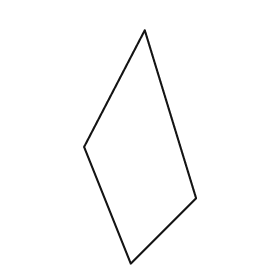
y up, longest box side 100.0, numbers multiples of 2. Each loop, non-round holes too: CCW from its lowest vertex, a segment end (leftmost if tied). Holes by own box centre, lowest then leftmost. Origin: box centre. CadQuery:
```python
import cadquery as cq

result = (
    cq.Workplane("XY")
    .moveTo(-4.0, -50.0)
    .lineTo(24.0, -22.0)
    .lineTo(2.0, 50.0)
    .lineTo(-24.0, 0.0)
    .close()
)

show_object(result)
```